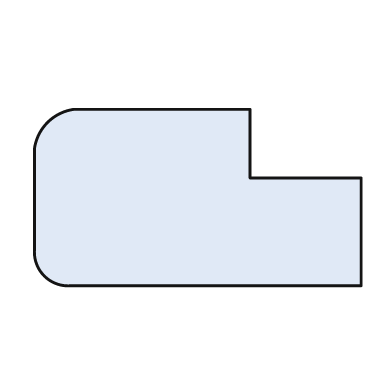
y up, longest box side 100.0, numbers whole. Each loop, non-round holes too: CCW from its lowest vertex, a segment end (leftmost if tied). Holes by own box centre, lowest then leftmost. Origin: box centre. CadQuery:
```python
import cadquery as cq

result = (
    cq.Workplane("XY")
    .moveTo(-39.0, -27.0)
    .lineTo(50.0, -27.0)
    .lineTo(50.0, 6.0)
    .lineTo(16.0, 6.0)
    .lineTo(16.0, 27.0)
    .lineTo(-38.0, 27.0)
    .threePointArc((-46.0, 23.0), (-50.0, 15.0))
    .lineTo(-50.0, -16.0)
    .threePointArc((-47.0, -24.0), (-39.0, -27.0))
    .close()
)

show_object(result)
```